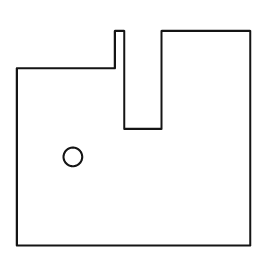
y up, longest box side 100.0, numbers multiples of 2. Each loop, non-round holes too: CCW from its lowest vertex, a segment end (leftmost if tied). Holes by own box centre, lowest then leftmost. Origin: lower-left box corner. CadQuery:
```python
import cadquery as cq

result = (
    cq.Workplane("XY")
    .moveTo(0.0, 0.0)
    .lineTo(100.0, 0.0)
    .lineTo(100.0, 92.0)
    .lineTo(62.0, 92.0)
    .lineTo(62.0, 50.0)
    .lineTo(46.0, 50.0)
    .lineTo(46.0, 92.0)
    .lineTo(42.0, 92.0)
    .lineTo(42.0, 76.0)
    .lineTo(0.0, 76.0)
    .close()
    .moveTo(24.0, 38.0)
    .circle(4.0)
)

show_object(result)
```